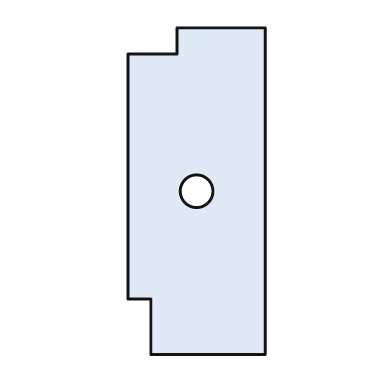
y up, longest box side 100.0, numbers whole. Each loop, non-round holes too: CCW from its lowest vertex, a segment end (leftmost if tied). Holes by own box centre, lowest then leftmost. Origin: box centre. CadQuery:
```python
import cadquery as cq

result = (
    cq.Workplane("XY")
    .moveTo(-14.0, -50.0)
    .lineTo(21.0, -50.0)
    .lineTo(21.0, 50.0)
    .lineTo(-6.0, 50.0)
    .lineTo(-6.0, 42.0)
    .lineTo(-21.0, 42.0)
    .lineTo(-21.0, -33.0)
    .lineTo(-14.0, -33.0)
    .close()
    .moveTo(0.0, 0.0)
    .circle(5.0)
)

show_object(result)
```